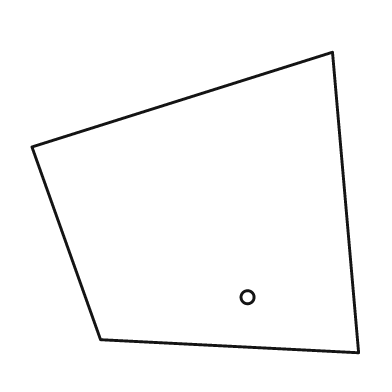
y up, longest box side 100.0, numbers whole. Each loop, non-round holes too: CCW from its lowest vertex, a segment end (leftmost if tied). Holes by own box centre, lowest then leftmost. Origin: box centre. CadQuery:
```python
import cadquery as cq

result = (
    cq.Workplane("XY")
    .moveTo(50.0, -46.0)
    .lineTo(42.0, 46.0)
    .lineTo(-50.0, 17.0)
    .lineTo(-29.0, -42.0)
    .close()
    .moveTo(16.0, -29.0)
    .circle(2.0)
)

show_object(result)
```